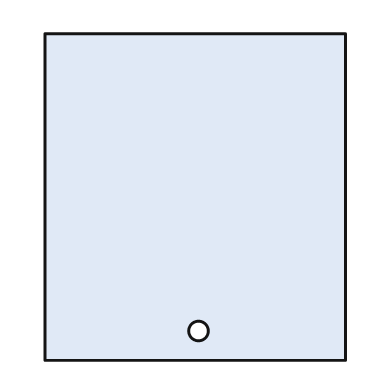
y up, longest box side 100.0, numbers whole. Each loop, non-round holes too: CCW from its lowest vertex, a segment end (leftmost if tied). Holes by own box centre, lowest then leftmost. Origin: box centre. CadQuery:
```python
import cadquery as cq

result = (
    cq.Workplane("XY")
    .moveTo(-46.0, -50.0)
    .lineTo(46.0, -50.0)
    .lineTo(46.0, 50.0)
    .lineTo(-46.0, 50.0)
    .close()
    .moveTo(1.0, -41.0)
    .circle(3.0)
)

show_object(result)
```